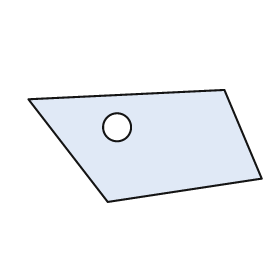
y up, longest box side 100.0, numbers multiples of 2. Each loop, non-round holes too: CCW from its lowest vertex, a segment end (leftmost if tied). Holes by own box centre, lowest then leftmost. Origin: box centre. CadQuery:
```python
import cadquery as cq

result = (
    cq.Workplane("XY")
    .moveTo(-16.0, -24.0)
    .lineTo(50.0, -14.0)
    .lineTo(34.0, 24.0)
    .lineTo(-50.0, 20.0)
    .close()
    .moveTo(-12.0, 8.0)
    .circle(6.0)
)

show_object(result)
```